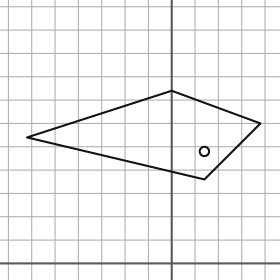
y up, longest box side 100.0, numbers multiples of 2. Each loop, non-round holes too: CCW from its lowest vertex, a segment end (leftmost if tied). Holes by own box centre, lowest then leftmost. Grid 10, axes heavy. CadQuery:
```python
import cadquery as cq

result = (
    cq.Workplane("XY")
    .moveTo(14.0, 36.0)
    .lineTo(38.0, 60.0)
    .lineTo(0.0, 74.0)
    .lineTo(-62.0, 54.0)
    .close()
    .moveTo(14.0, 48.0)
    .circle(2.0)
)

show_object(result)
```